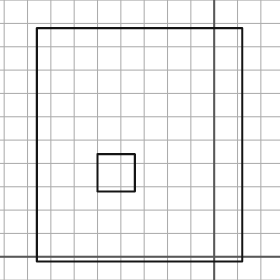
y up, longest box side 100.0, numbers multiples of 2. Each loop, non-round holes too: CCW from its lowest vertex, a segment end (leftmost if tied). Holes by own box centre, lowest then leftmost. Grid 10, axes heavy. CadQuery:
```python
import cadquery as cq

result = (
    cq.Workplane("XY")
    .moveTo(-76.0, -2.0)
    .lineTo(12.0, -2.0)
    .lineTo(12.0, 98.0)
    .lineTo(-76.0, 98.0)
    .close()
    .moveTo(-50.0, 28.0)
    .lineTo(-34.0, 28.0)
    .lineTo(-34.0, 44.0)
    .lineTo(-50.0, 44.0)
    .close()
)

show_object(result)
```